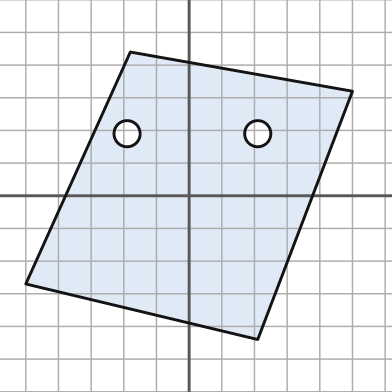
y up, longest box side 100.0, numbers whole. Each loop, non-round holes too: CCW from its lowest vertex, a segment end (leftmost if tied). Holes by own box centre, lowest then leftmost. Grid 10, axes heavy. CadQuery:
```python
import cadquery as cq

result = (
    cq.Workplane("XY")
    .moveTo(21.0, -44.0)
    .lineTo(50.0, 32.0)
    .lineTo(-18.0, 44.0)
    .lineTo(-50.0, -27.0)
    .close()
    .moveTo(-19.0, 19.0)
    .circle(4.0)
    .moveTo(21.0, 19.0)
    .circle(4.0)
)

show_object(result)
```